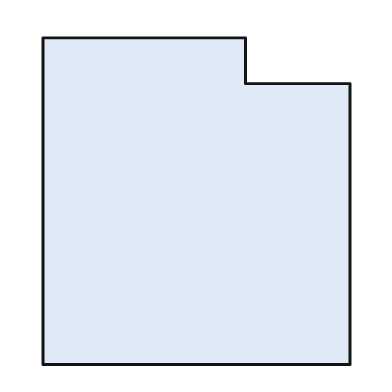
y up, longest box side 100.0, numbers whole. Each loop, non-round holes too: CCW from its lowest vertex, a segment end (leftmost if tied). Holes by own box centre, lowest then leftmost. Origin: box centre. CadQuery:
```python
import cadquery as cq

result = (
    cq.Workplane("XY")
    .moveTo(-47.0, -50.0)
    .lineTo(47.0, -50.0)
    .lineTo(47.0, 36.0)
    .lineTo(15.0, 36.0)
    .lineTo(15.0, 50.0)
    .lineTo(-47.0, 50.0)
    .close()
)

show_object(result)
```